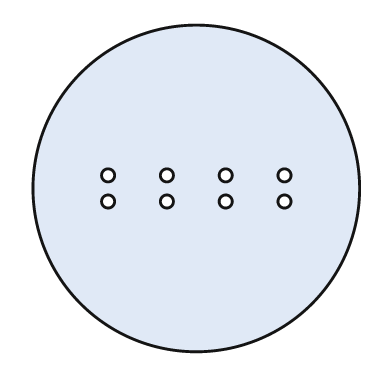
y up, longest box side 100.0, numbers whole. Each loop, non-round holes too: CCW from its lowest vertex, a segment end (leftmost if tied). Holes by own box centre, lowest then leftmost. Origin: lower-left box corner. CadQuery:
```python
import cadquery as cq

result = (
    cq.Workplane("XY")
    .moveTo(50.0, 50.0)
    .circle(50.0)
    .moveTo(23.0, 46.0)
    .circle(2.0)
    .moveTo(41.0, 46.0)
    .circle(2.0)
    .moveTo(59.0, 46.0)
    .circle(2.0)
    .moveTo(77.0, 46.0)
    .circle(2.0)
    .moveTo(23.0, 54.0)
    .circle(2.0)
    .moveTo(41.0, 54.0)
    .circle(2.0)
    .moveTo(59.0, 54.0)
    .circle(2.0)
    .moveTo(77.0, 54.0)
    .circle(2.0)
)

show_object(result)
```